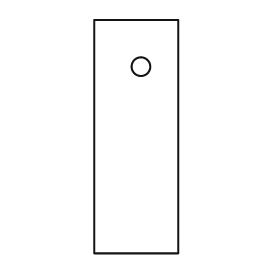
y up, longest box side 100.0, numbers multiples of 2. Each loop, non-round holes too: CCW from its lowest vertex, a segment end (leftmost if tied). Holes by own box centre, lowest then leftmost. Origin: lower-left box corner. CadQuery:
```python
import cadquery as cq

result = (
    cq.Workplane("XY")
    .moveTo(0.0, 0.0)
    .lineTo(36.0, 0.0)
    .lineTo(36.0, 100.0)
    .lineTo(0.0, 100.0)
    .close()
    .moveTo(20.0, 80.0)
    .circle(4.0)
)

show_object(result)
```